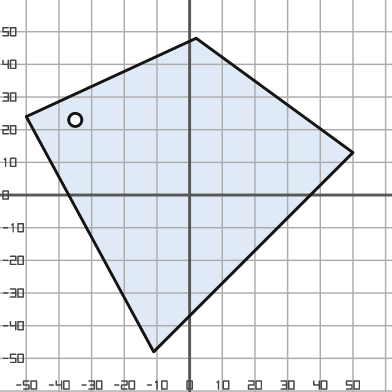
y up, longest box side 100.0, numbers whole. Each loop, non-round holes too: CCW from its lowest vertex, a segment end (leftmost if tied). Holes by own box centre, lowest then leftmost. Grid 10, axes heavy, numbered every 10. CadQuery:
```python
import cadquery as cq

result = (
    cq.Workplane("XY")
    .moveTo(-11.0, -48.0)
    .lineTo(50.0, 13.0)
    .lineTo(2.0, 48.0)
    .lineTo(-50.0, 24.0)
    .close()
    .moveTo(-35.0, 23.0)
    .circle(2.0)
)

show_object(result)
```